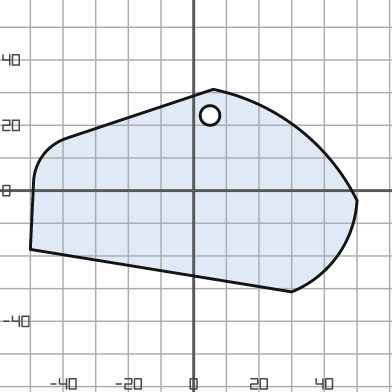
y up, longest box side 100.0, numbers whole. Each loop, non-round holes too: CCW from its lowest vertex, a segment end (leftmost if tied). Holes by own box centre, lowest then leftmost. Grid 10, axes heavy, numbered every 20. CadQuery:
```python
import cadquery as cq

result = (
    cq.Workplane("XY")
    .moveTo(30.0, -31.0)
    .threePointArc((44.0, -20.0), (50.0, -3.0))
    .threePointArc((32.0, 19.0), (6.0, 31.0))
    .lineTo(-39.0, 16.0)
    .threePointArc((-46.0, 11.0), (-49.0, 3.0))
    .lineTo(-50.0, -18.0)
    .close()
    .moveTo(5.0, 23.0)
    .circle(3.0)
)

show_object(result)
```